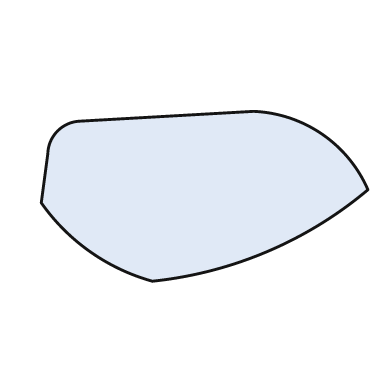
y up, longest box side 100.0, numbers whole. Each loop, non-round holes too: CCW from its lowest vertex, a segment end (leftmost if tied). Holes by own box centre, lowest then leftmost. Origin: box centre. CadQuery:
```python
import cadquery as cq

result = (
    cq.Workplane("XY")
    .moveTo(-16.0, -26.0)
    .threePointArc((19.0, -17.0), (50.0, 2.0))
    .threePointArc((36.0, 19.0), (15.0, 26.0))
    .lineTo(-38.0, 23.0)
    .threePointArc((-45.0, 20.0), (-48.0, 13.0))
    .lineTo(-50.0, -2.0)
    .threePointArc((-35.0, -17.0), (-16.0, -26.0))
    .close()
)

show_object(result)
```